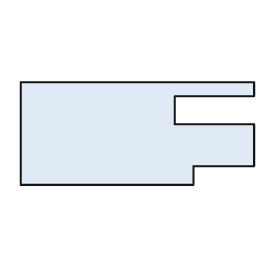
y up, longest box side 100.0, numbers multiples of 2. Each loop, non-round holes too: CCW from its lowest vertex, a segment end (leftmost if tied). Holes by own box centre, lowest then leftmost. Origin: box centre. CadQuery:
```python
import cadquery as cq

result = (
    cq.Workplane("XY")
    .moveTo(-50.0, -22.0)
    .lineTo(24.0, -22.0)
    .lineTo(24.0, -14.0)
    .lineTo(50.0, -14.0)
    .lineTo(50.0, 4.0)
    .lineTo(16.0, 4.0)
    .lineTo(16.0, 16.0)
    .lineTo(50.0, 16.0)
    .lineTo(50.0, 22.0)
    .lineTo(-50.0, 22.0)
    .close()
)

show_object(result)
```